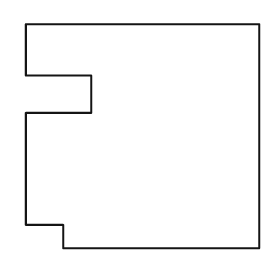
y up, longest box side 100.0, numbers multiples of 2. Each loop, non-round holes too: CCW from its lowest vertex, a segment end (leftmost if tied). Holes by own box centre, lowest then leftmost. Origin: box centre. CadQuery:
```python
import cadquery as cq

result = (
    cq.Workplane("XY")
    .moveTo(-34.0, -48.0)
    .lineTo(50.0, -48.0)
    .lineTo(50.0, 48.0)
    .lineTo(-50.0, 48.0)
    .lineTo(-50.0, 26.0)
    .lineTo(-22.0, 26.0)
    .lineTo(-22.0, 10.0)
    .lineTo(-50.0, 10.0)
    .lineTo(-50.0, -38.0)
    .lineTo(-34.0, -38.0)
    .close()
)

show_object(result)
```